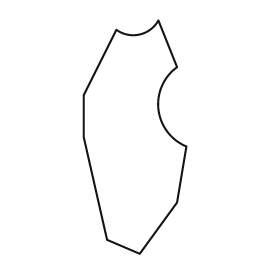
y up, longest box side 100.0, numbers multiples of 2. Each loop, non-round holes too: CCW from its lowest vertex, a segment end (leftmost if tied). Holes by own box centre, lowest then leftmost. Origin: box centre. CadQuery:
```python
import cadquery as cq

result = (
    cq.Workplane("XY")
    .moveTo(2.0, -50.0)
    .lineTo(18.0, -28.0)
    .lineTo(22.0, -4.0)
    .threePointArc((10.0, 12.0), (18.0, 30.0))
    .lineTo(10.0, 50.0)
    .threePointArc((2.0, 44.0), (-8.0, 46.0))
    .lineTo(-22.0, 18.0)
    .lineTo(-22.0, 0.0)
    .lineTo(-12.0, -44.0)
    .close()
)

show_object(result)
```